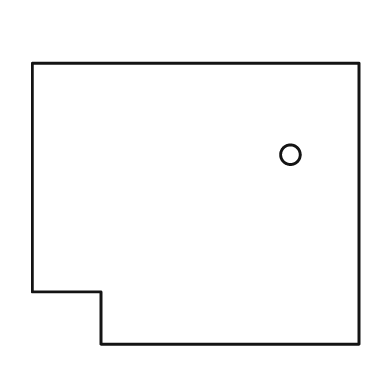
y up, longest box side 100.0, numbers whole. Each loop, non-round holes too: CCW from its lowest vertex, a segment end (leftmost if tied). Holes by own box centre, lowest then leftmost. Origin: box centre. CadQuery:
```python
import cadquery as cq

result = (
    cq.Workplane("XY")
    .moveTo(-29.0, -43.0)
    .lineTo(50.0, -43.0)
    .lineTo(50.0, 43.0)
    .lineTo(-50.0, 43.0)
    .lineTo(-50.0, -27.0)
    .lineTo(-29.0, -27.0)
    .close()
    .moveTo(29.0, 15.0)
    .circle(3.0)
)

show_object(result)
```